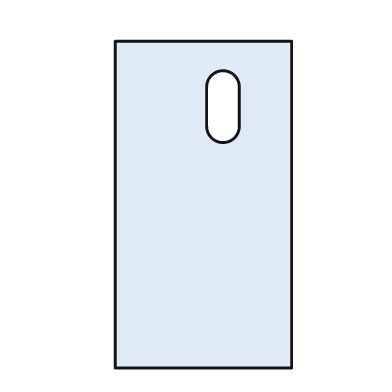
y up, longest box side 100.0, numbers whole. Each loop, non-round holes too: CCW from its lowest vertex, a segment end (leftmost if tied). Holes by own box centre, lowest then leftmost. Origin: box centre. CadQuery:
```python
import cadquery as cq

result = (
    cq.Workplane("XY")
    .moveTo(-27.0, -50.0)
    .lineTo(27.0, -50.0)
    .lineTo(27.0, 50.0)
    .lineTo(-27.0, 50.0)
    .close()
    .moveTo(1.0, 24.0)
    .threePointArc((6.0, 19.0), (11.0, 24.0))
    .lineTo(11.0, 36.0)
    .threePointArc((6.0, 41.0), (1.0, 36.0))
    .close()
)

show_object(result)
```